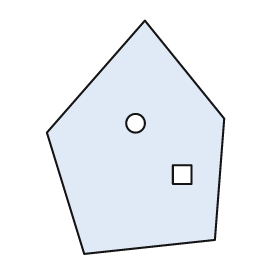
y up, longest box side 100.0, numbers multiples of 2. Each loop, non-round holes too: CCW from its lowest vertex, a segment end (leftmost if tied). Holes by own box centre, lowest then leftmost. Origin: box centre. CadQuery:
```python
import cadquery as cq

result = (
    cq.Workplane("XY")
    .moveTo(-22.0, -50.0)
    .lineTo(34.0, -44.0)
    .lineTo(38.0, 8.0)
    .lineTo(4.0, 50.0)
    .lineTo(-38.0, 2.0)
    .close()
    .moveTo(16.0, -20.0)
    .lineTo(24.0, -20.0)
    .lineTo(24.0, -12.0)
    .lineTo(16.0, -12.0)
    .close()
    .moveTo(0.0, 6.0)
    .circle(4.0)
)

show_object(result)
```